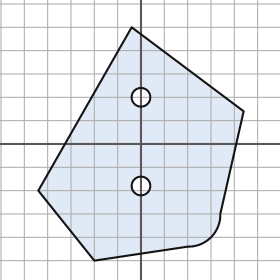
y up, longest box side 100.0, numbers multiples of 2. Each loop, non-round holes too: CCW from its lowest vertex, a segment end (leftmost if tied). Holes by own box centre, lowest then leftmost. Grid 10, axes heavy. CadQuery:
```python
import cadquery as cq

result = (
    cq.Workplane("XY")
    .moveTo(-20.0, -50.0)
    .lineTo(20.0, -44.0)
    .threePointArc((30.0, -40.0), (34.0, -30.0))
    .lineTo(44.0, 14.0)
    .lineTo(-4.0, 50.0)
    .lineTo(-44.0, -20.0)
    .close()
    .moveTo(0.0, -18.0)
    .circle(4.0)
    .moveTo(0.0, 20.0)
    .circle(4.0)
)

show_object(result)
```